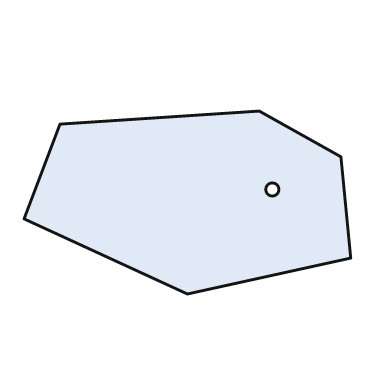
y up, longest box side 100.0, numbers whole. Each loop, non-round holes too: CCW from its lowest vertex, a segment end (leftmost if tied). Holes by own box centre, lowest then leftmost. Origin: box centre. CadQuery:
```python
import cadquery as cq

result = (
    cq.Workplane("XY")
    .moveTo(0.0, -28.0)
    .lineTo(50.0, -17.0)
    .lineTo(47.0, 14.0)
    .lineTo(22.0, 28.0)
    .lineTo(-39.0, 24.0)
    .lineTo(-50.0, -5.0)
    .close()
    .moveTo(26.0, 4.0)
    .circle(2.0)
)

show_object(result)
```